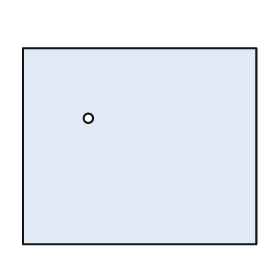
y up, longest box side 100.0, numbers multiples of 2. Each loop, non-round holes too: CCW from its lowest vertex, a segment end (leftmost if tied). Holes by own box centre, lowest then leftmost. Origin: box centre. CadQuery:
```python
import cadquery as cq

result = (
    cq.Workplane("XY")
    .moveTo(-50.0, -42.0)
    .lineTo(50.0, -42.0)
    .lineTo(50.0, 42.0)
    .lineTo(-50.0, 42.0)
    .close()
    .moveTo(-22.0, 12.0)
    .circle(2.0)
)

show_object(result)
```